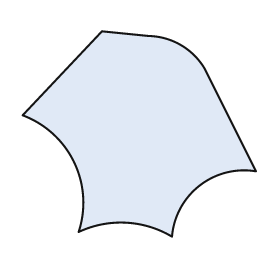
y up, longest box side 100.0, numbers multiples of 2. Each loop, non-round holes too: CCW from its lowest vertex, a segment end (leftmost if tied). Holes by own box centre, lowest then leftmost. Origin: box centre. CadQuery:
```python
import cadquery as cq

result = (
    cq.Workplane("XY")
    .moveTo(14.0, -44.0)
    .threePointArc((26.0, -22.0), (50.0, -16.0))
    .lineTo(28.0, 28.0)
    .threePointArc((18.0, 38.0), (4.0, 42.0))
    .lineTo(-16.0, 44.0)
    .lineTo(-50.0, 8.0)
    .threePointArc((-28.0, -12.0), (-26.0, -42.0))
    .threePointArc((-6.0, -38.0), (14.0, -44.0))
    .close()
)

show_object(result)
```